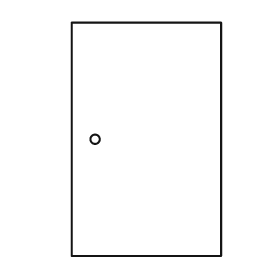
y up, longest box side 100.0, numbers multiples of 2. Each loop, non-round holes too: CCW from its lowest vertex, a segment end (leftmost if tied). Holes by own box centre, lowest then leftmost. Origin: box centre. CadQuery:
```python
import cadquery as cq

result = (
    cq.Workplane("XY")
    .moveTo(-32.0, -50.0)
    .lineTo(32.0, -50.0)
    .lineTo(32.0, 50.0)
    .lineTo(-32.0, 50.0)
    .close()
    .moveTo(-22.0, 0.0)
    .circle(2.0)
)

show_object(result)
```